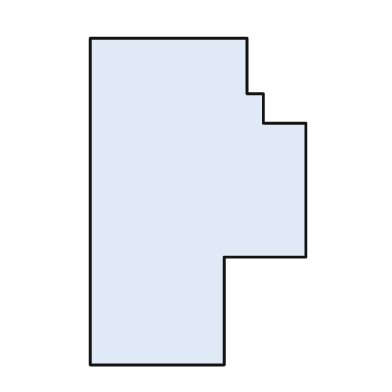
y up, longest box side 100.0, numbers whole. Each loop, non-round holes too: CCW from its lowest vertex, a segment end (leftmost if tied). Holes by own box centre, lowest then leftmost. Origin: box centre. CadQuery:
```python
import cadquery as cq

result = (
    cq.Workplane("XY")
    .moveTo(-33.0, -50.0)
    .lineTo(8.0, -50.0)
    .lineTo(8.0, -17.0)
    .lineTo(33.0, -17.0)
    .lineTo(33.0, 24.0)
    .lineTo(20.0, 24.0)
    .lineTo(20.0, 33.0)
    .lineTo(15.0, 33.0)
    .lineTo(15.0, 50.0)
    .lineTo(-33.0, 50.0)
    .close()
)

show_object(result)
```